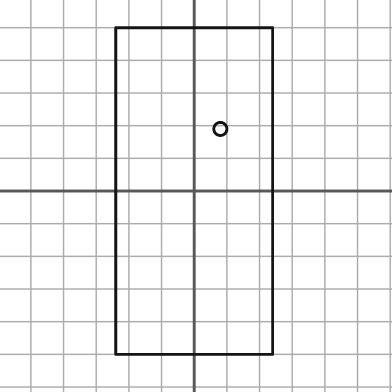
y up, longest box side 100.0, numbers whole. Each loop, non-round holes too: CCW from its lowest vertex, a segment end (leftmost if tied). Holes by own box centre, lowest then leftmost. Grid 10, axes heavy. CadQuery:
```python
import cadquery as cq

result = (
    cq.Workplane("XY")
    .moveTo(-24.0, -50.0)
    .lineTo(24.0, -50.0)
    .lineTo(24.0, 50.0)
    .lineTo(-24.0, 50.0)
    .close()
    .moveTo(8.0, 19.0)
    .circle(2.0)
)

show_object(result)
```